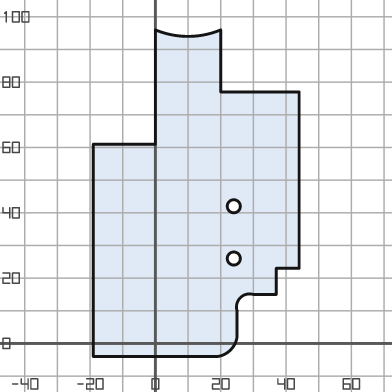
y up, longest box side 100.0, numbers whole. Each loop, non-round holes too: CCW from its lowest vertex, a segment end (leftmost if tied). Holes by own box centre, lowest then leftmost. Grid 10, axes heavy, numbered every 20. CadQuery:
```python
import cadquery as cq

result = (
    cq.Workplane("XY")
    .moveTo(-19.0, -4.0)
    .lineTo(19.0, -4.0)
    .threePointArc((23.0, -2.0), (25.0, 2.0))
    .lineTo(25.0, 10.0)
    .threePointArc((26.0, 14.0), (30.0, 15.0))
    .lineTo(37.0, 15.0)
    .lineTo(37.0, 23.0)
    .lineTo(44.0, 23.0)
    .lineTo(44.0, 77.0)
    .lineTo(20.0, 77.0)
    .lineTo(20.0, 96.0)
    .threePointArc((10.0, 94.0), (0.0, 96.0))
    .lineTo(0.0, 61.0)
    .lineTo(-19.0, 61.0)
    .close()
    .moveTo(24.0, 26.0)
    .circle(2.0)
    .moveTo(24.0, 42.0)
    .circle(2.0)
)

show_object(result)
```